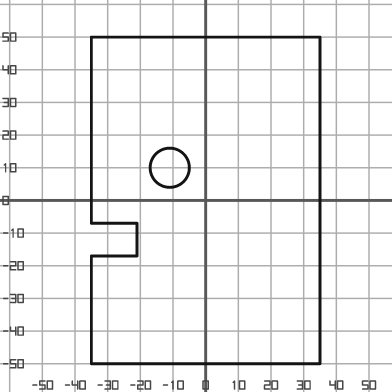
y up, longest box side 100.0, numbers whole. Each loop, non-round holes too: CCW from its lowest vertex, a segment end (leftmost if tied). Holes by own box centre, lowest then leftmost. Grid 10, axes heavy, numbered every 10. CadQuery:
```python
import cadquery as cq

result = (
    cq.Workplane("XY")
    .moveTo(-35.0, -50.0)
    .lineTo(35.0, -50.0)
    .lineTo(35.0, 50.0)
    .lineTo(-35.0, 50.0)
    .lineTo(-35.0, -7.0)
    .lineTo(-21.0, -7.0)
    .lineTo(-21.0, -17.0)
    .lineTo(-35.0, -17.0)
    .close()
    .moveTo(-11.0, 10.0)
    .circle(6.0)
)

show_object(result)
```